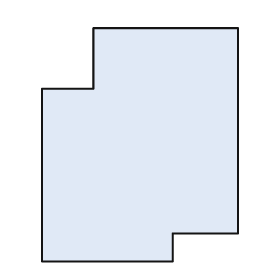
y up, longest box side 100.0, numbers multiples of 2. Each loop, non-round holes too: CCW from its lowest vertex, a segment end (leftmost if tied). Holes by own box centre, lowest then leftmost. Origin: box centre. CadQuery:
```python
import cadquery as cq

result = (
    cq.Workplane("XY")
    .moveTo(-42.0, -50.0)
    .lineTo(14.0, -50.0)
    .lineTo(14.0, -38.0)
    .lineTo(42.0, -38.0)
    .lineTo(42.0, 50.0)
    .lineTo(-20.0, 50.0)
    .lineTo(-20.0, 24.0)
    .lineTo(-42.0, 24.0)
    .close()
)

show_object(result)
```